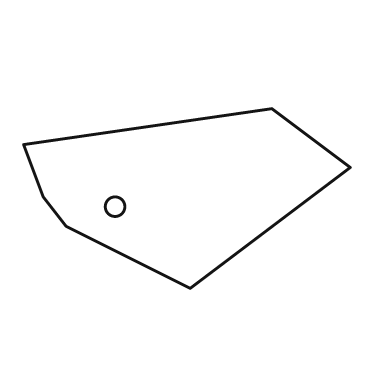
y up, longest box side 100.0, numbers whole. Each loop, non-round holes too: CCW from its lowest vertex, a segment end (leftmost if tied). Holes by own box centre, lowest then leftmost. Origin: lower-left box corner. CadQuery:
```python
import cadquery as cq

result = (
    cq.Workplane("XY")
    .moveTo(51.0, 0.0)
    .lineTo(100.0, 37.0)
    .lineTo(76.0, 55.0)
    .lineTo(0.0, 44.0)
    .lineTo(6.0, 28.0)
    .lineTo(13.0, 19.0)
    .close()
    .moveTo(28.0, 25.0)
    .circle(3.0)
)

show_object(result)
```